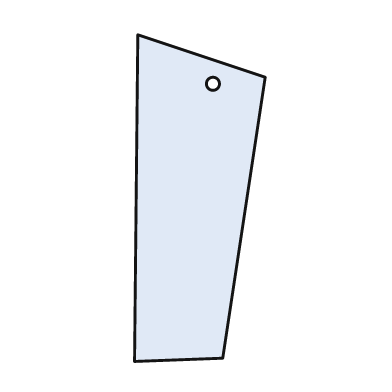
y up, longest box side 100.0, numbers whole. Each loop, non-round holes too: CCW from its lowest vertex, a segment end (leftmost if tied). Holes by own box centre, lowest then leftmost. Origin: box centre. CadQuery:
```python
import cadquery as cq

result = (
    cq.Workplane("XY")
    .moveTo(-20.0, -50.0)
    .lineTo(7.0, -49.0)
    .lineTo(20.0, 37.0)
    .lineTo(-19.0, 50.0)
    .close()
    .moveTo(4.0, 35.0)
    .circle(2.0)
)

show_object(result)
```